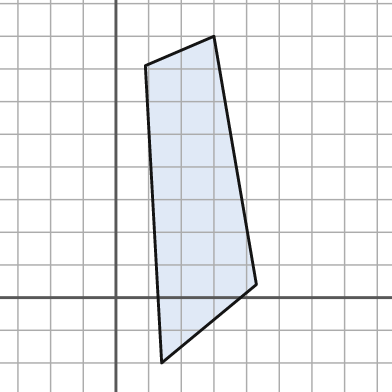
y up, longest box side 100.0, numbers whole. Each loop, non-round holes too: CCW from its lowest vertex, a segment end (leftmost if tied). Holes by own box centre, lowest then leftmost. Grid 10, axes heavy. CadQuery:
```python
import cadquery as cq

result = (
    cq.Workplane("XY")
    .moveTo(14.0, -20.0)
    .lineTo(43.0, 4.0)
    .lineTo(30.0, 80.0)
    .lineTo(9.0, 71.0)
    .close()
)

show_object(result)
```